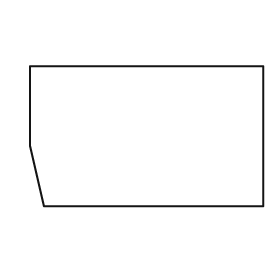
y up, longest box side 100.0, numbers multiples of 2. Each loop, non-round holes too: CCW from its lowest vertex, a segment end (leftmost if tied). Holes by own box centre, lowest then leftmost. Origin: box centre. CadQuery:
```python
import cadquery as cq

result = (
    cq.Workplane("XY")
    .moveTo(-44.0, -30.0)
    .lineTo(50.0, -30.0)
    .lineTo(50.0, 30.0)
    .lineTo(-50.0, 30.0)
    .lineTo(-50.0, -4.0)
    .close()
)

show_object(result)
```